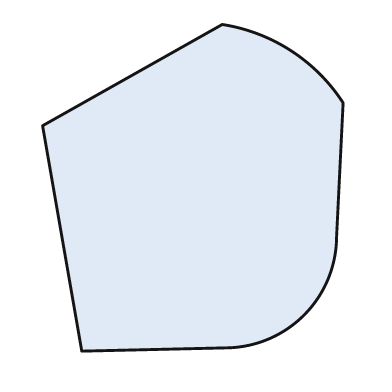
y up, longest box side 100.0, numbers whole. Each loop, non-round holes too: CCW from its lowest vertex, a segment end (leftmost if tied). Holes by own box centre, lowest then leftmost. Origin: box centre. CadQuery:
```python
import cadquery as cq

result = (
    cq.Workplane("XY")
    .moveTo(-34.0, -50.0)
    .lineTo(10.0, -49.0)
    .threePointArc((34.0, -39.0), (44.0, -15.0))
    .lineTo(46.0, 26.0)
    .threePointArc((30.0, 42.0), (9.0, 50.0))
    .lineTo(-46.0, 19.0)
    .close()
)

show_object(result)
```